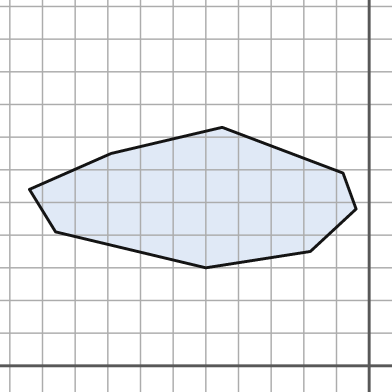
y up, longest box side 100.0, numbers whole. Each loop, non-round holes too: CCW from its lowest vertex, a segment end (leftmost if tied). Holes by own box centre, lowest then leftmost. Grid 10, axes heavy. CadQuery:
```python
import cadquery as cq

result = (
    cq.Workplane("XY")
    .moveTo(-50.0, 30.0)
    .lineTo(-18.0, 35.0)
    .lineTo(-4.0, 48.0)
    .lineTo(-8.0, 59.0)
    .lineTo(-45.0, 73.0)
    .lineTo(-79.0, 65.0)
    .lineTo(-104.0, 54.0)
    .lineTo(-96.0, 41.0)
    .close()
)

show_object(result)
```